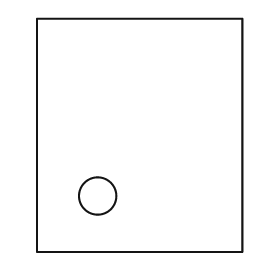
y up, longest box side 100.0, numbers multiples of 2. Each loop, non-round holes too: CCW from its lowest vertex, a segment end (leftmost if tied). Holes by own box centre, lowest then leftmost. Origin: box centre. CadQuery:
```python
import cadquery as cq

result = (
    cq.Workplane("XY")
    .moveTo(-44.0, -50.0)
    .lineTo(44.0, -50.0)
    .lineTo(44.0, 50.0)
    .lineTo(-44.0, 50.0)
    .close()
    .moveTo(-18.0, -26.0)
    .circle(8.0)
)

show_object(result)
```